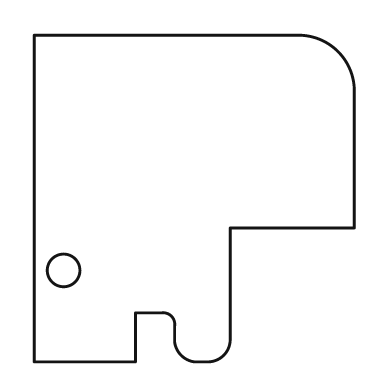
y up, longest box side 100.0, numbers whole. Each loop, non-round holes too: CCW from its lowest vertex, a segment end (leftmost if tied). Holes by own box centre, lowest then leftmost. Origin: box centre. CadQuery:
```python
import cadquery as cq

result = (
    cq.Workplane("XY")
    .moveTo(-49.0, -50.0)
    .lineTo(-18.0, -50.0)
    .lineTo(-18.0, -35.0)
    .lineTo(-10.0, -35.0)
    .threePointArc((-7.0, -36.0), (-6.0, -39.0))
    .lineTo(-6.0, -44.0)
    .threePointArc((-4.0, -48.0), (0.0, -50.0))
    .lineTo(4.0, -50.0)
    .threePointArc((9.0, -48.0), (11.0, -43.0))
    .lineTo(11.0, -9.0)
    .lineTo(49.0, -9.0)
    .lineTo(49.0, 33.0)
    .threePointArc((44.0, 45.0), (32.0, 50.0))
    .lineTo(-49.0, 50.0)
    .close()
    .moveTo(-40.0, -22.0)
    .circle(5.0)
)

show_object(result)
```